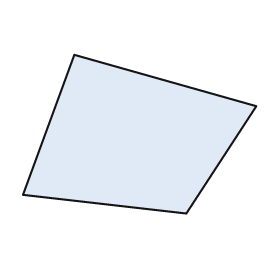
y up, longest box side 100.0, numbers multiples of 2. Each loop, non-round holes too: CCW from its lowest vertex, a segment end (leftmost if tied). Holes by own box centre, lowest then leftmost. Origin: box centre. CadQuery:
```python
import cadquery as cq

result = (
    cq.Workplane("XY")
    .moveTo(20.0, -34.0)
    .lineTo(50.0, 12.0)
    .lineTo(-28.0, 34.0)
    .lineTo(-50.0, -26.0)
    .close()
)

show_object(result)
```